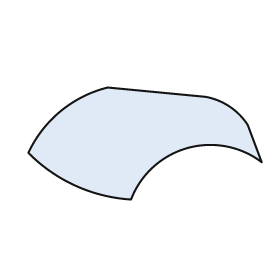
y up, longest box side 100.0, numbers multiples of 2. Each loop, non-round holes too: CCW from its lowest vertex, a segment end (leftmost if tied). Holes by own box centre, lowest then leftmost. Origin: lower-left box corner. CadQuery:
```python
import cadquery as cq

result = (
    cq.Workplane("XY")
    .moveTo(44.0, 0.0)
    .threePointArc((68.0, 22.0), (100.0, 16.0))
    .lineTo(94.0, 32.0)
    .threePointArc((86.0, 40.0), (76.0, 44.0))
    .lineTo(34.0, 48.0)
    .threePointArc((14.0, 38.0), (0.0, 20.0))
    .threePointArc((20.0, 6.0), (44.0, 0.0))
    .close()
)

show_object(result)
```